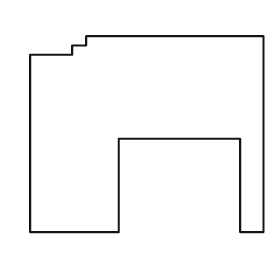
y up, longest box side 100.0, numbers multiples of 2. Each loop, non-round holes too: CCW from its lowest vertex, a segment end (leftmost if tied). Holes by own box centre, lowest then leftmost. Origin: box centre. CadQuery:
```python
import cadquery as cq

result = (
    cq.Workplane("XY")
    .moveTo(-50.0, -42.0)
    .lineTo(-12.0, -42.0)
    .lineTo(-12.0, -2.0)
    .lineTo(40.0, -2.0)
    .lineTo(40.0, -42.0)
    .lineTo(50.0, -42.0)
    .lineTo(50.0, 42.0)
    .lineTo(-26.0, 42.0)
    .lineTo(-26.0, 38.0)
    .lineTo(-32.0, 38.0)
    .lineTo(-32.0, 34.0)
    .lineTo(-50.0, 34.0)
    .close()
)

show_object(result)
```